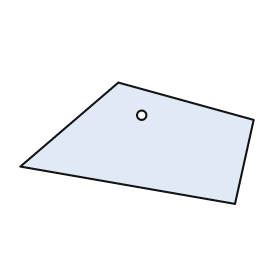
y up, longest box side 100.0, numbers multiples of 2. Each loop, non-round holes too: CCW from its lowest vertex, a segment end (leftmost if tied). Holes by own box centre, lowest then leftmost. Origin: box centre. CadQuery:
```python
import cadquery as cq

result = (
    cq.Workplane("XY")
    .moveTo(42.0, -26.0)
    .lineTo(50.0, 10.0)
    .lineTo(-8.0, 26.0)
    .lineTo(-50.0, -10.0)
    .close()
    .moveTo(2.0, 12.0)
    .circle(2.0)
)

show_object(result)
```